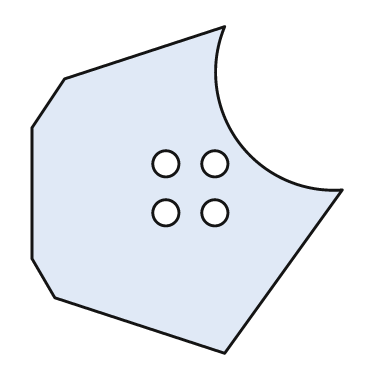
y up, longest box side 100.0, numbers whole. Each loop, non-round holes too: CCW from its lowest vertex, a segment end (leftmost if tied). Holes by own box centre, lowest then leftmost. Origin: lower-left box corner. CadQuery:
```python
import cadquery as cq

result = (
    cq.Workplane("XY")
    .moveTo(59.0, 0.0)
    .lineTo(95.0, 50.0)
    .threePointArc((63.0, 65.0), (59.0, 100.0))
    .lineTo(10.0, 84.0)
    .lineTo(0.0, 69.0)
    .lineTo(0.0, 29.0)
    .lineTo(7.0, 17.0)
    .close()
    .moveTo(41.0, 43.0)
    .circle(4.0)
    .moveTo(56.0, 43.0)
    .circle(4.0)
    .moveTo(41.0, 58.0)
    .circle(4.0)
    .moveTo(56.0, 58.0)
    .circle(4.0)
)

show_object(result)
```